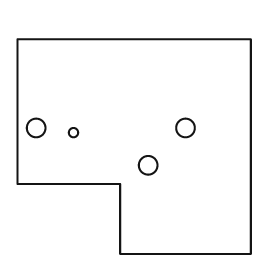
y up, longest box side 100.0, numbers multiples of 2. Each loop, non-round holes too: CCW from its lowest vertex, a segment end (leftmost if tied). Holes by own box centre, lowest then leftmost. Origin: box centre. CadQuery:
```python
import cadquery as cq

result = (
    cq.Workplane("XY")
    .moveTo(-6.0, -46.0)
    .lineTo(50.0, -46.0)
    .lineTo(50.0, 46.0)
    .lineTo(-50.0, 46.0)
    .lineTo(-50.0, -16.0)
    .lineTo(-6.0, -16.0)
    .close()
    .moveTo(6.0, -8.0)
    .circle(4.0)
    .moveTo(-26.0, 6.0)
    .circle(2.0)
    .moveTo(-42.0, 8.0)
    .circle(4.0)
    .moveTo(22.0, 8.0)
    .circle(4.0)
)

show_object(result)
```